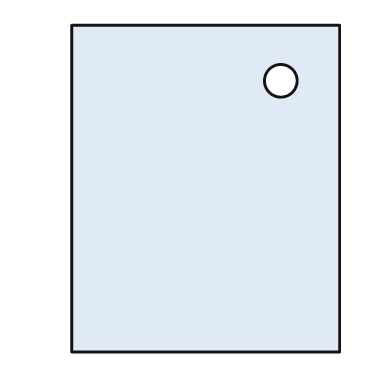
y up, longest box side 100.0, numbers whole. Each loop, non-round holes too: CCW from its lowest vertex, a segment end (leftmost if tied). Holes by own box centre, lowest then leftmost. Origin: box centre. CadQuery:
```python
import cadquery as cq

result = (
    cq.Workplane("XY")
    .moveTo(-41.0, -50.0)
    .lineTo(41.0, -50.0)
    .lineTo(41.0, 50.0)
    .lineTo(-41.0, 50.0)
    .close()
    .moveTo(23.0, 33.0)
    .circle(5.0)
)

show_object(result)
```